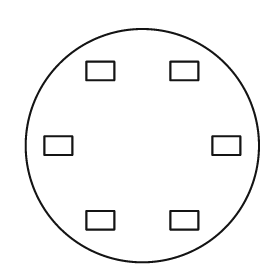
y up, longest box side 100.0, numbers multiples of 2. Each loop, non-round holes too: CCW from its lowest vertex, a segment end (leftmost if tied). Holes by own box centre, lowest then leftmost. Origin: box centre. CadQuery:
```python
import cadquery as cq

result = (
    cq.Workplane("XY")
    .moveTo(0.0, 0.0)
    .circle(50.0)
    .moveTo(-24.0, -36.0)
    .lineTo(-12.0, -36.0)
    .lineTo(-12.0, -28.0)
    .lineTo(-24.0, -28.0)
    .close()
    .moveTo(12.0, -36.0)
    .lineTo(24.0, -36.0)
    .lineTo(24.0, -28.0)
    .lineTo(12.0, -28.0)
    .close()
    .moveTo(-42.0, -4.0)
    .lineTo(-30.0, -4.0)
    .lineTo(-30.0, 4.0)
    .lineTo(-42.0, 4.0)
    .close()
    .moveTo(30.0, -4.0)
    .lineTo(42.0, -4.0)
    .lineTo(42.0, 4.0)
    .lineTo(30.0, 4.0)
    .close()
    .moveTo(-24.0, 28.0)
    .lineTo(-12.0, 28.0)
    .lineTo(-12.0, 36.0)
    .lineTo(-24.0, 36.0)
    .close()
    .moveTo(12.0, 28.0)
    .lineTo(24.0, 28.0)
    .lineTo(24.0, 36.0)
    .lineTo(12.0, 36.0)
    .close()
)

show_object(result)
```